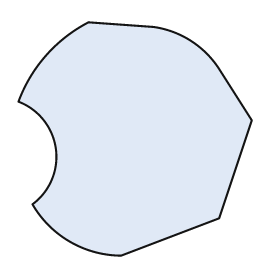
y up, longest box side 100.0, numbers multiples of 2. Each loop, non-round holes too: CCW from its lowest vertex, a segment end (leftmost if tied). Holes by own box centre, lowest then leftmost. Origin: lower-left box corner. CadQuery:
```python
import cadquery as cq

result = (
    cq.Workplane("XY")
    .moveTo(44.0, 0.0)
    .lineTo(86.0, 16.0)
    .lineTo(100.0, 58.0)
    .lineTo(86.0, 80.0)
    .threePointArc((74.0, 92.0), (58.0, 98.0))
    .lineTo(30.0, 100.0)
    .threePointArc((12.0, 86.0), (0.0, 66.0))
    .threePointArc((16.0, 46.0), (6.0, 22.0))
    .threePointArc((22.0, 6.0), (44.0, 0.0))
    .close()
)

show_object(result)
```